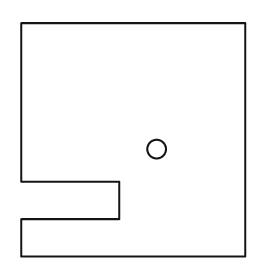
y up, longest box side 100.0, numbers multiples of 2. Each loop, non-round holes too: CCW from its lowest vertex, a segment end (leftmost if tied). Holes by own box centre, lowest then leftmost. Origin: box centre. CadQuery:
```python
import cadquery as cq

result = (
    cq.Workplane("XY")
    .moveTo(-48.0, -50.0)
    .lineTo(48.0, -50.0)
    .lineTo(48.0, 50.0)
    .lineTo(-48.0, 50.0)
    .lineTo(-48.0, -18.0)
    .lineTo(-6.0, -18.0)
    .lineTo(-6.0, -34.0)
    .lineTo(-48.0, -34.0)
    .close()
    .moveTo(10.0, -4.0)
    .circle(4.0)
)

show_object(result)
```